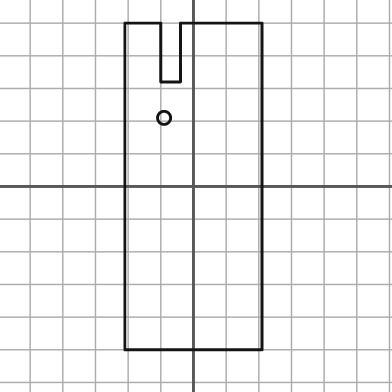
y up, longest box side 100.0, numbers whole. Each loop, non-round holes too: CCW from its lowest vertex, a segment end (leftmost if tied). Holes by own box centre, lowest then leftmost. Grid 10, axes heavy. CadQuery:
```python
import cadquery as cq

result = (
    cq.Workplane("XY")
    .moveTo(-21.0, -50.0)
    .lineTo(21.0, -50.0)
    .lineTo(21.0, 50.0)
    .lineTo(-4.0, 50.0)
    .lineTo(-4.0, 32.0)
    .lineTo(-10.0, 32.0)
    .lineTo(-10.0, 50.0)
    .lineTo(-21.0, 50.0)
    .close()
    .moveTo(-9.0, 21.0)
    .circle(2.0)
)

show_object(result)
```